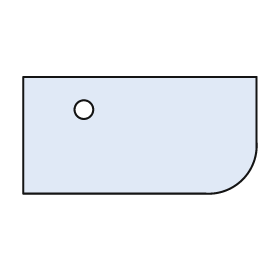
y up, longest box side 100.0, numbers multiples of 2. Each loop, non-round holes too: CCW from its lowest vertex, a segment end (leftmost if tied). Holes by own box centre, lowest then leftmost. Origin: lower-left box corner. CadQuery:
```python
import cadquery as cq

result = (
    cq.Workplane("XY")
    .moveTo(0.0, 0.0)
    .lineTo(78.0, 0.0)
    .threePointArc((94.0, 6.0), (100.0, 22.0))
    .lineTo(100.0, 50.0)
    .lineTo(0.0, 50.0)
    .close()
    .moveTo(26.0, 36.0)
    .circle(4.0)
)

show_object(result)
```